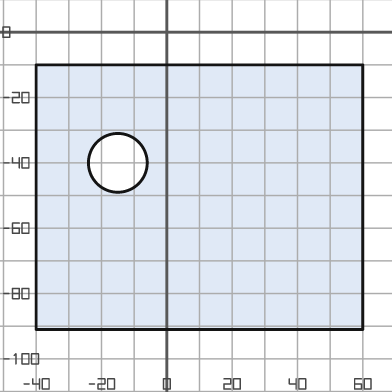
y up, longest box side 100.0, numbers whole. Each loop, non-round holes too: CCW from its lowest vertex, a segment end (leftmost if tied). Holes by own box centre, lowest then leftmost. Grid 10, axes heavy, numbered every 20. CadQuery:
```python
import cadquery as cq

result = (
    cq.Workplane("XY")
    .moveTo(-40.0, -91.0)
    .lineTo(60.0, -91.0)
    .lineTo(60.0, -10.0)
    .lineTo(-40.0, -10.0)
    .close()
    .moveTo(-15.0, -40.0)
    .circle(9.0)
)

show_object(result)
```